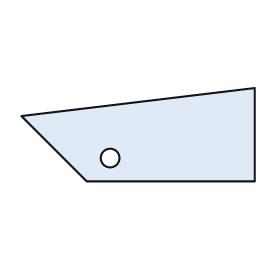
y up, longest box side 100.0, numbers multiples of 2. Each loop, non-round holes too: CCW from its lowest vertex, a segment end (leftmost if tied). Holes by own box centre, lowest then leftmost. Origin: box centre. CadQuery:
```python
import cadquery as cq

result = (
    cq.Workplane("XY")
    .moveTo(-22.0, -20.0)
    .lineTo(50.0, -20.0)
    .lineTo(50.0, 20.0)
    .lineTo(-50.0, 8.0)
    .close()
    .moveTo(-12.0, -10.0)
    .circle(4.0)
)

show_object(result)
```